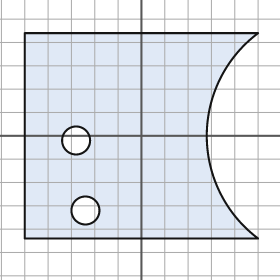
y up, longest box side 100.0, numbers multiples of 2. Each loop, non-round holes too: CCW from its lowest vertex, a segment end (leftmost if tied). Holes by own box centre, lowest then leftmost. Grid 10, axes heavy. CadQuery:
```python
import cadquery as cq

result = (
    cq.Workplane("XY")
    .moveTo(-50.0, -44.0)
    .lineTo(50.0, -44.0)
    .threePointArc((28.0, 0.0), (50.0, 44.0))
    .lineTo(-50.0, 44.0)
    .close()
    .moveTo(-24.0, -32.0)
    .circle(6.0)
    .moveTo(-28.0, -2.0)
    .circle(6.0)
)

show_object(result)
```